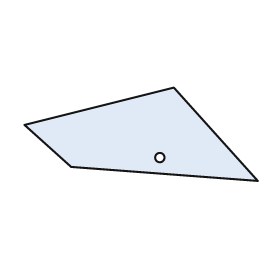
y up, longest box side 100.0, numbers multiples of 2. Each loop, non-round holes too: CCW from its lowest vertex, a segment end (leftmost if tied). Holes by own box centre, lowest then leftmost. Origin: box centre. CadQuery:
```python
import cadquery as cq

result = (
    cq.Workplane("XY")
    .moveTo(50.0, -20.0)
    .lineTo(14.0, 20.0)
    .lineTo(-50.0, 4.0)
    .lineTo(-30.0, -14.0)
    .close()
    .moveTo(8.0, -10.0)
    .circle(2.0)
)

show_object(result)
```